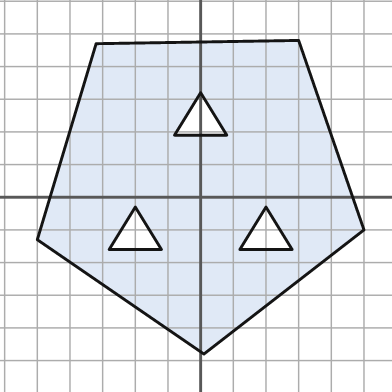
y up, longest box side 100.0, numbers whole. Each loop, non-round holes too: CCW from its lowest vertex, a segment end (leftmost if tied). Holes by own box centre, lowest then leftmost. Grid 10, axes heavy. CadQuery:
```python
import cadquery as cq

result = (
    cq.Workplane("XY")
    .moveTo(1.0, -48.0)
    .lineTo(50.0, -10.0)
    .lineTo(30.0, 48.0)
    .lineTo(-32.0, 47.0)
    .lineTo(-50.0, -13.0)
    .close()
    .moveTo(-28.0, -16.0)
    .lineTo(-12.0, -16.0)
    .lineTo(-20.0, -3.0)
    .close()
    .moveTo(12.0, -16.0)
    .lineTo(28.0, -16.0)
    .lineTo(20.0, -3.0)
    .close()
    .moveTo(-8.0, 19.0)
    .lineTo(8.0, 19.0)
    .lineTo(0.0, 32.0)
    .close()
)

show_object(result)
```